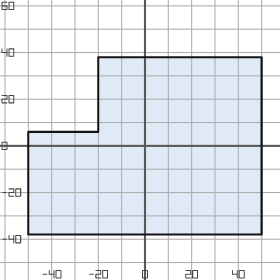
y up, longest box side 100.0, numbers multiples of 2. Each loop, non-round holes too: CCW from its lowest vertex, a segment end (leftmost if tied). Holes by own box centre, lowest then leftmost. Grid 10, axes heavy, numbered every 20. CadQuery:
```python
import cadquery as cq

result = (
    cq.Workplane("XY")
    .moveTo(-50.0, -38.0)
    .lineTo(50.0, -38.0)
    .lineTo(50.0, 38.0)
    .lineTo(-20.0, 38.0)
    .lineTo(-20.0, 6.0)
    .lineTo(-50.0, 6.0)
    .close()
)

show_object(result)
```